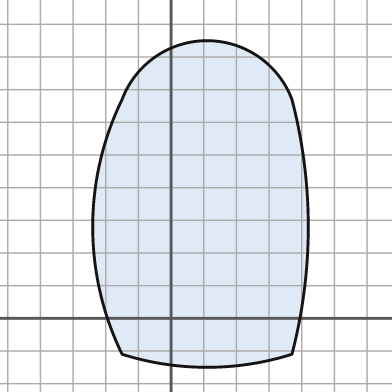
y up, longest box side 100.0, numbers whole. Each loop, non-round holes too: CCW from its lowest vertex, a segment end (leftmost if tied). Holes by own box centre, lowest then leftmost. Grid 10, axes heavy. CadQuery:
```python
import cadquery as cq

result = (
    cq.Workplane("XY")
    .moveTo(-15.0, -11.0)
    .threePointArc((11.0, -15.0), (37.0, -11.0))
    .threePointArc((42.0, 28.0), (37.0, 67.0))
    .threePointArc((11.0, 85.0), (-15.0, 67.0))
    .threePointArc((-24.0, 28.0), (-15.0, -11.0))
    .close()
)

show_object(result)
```